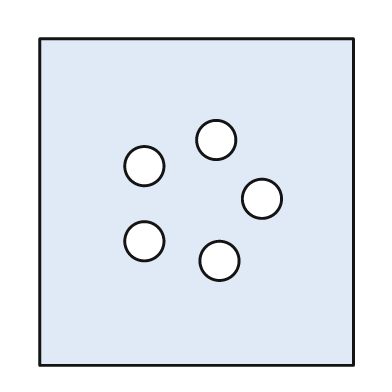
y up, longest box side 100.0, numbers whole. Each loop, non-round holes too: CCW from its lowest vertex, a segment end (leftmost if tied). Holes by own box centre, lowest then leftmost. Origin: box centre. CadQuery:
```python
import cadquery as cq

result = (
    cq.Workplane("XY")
    .moveTo(-48.0, -50.0)
    .lineTo(48.0, -50.0)
    .lineTo(48.0, 50.0)
    .lineTo(-48.0, 50.0)
    .close()
    .moveTo(7.0, -18.0)
    .circle(6.0)
    .moveTo(-16.0, -12.0)
    .circle(6.0)
    .moveTo(20.0, 1.0)
    .circle(6.0)
    .moveTo(-16.0, 11.0)
    .circle(6.0)
    .moveTo(6.0, 19.0)
    .circle(6.0)
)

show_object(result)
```